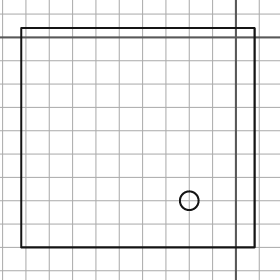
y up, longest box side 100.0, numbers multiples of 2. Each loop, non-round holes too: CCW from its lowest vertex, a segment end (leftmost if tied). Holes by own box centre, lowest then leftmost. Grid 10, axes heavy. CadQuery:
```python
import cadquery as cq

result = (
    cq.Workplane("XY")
    .moveTo(-92.0, -90.0)
    .lineTo(8.0, -90.0)
    .lineTo(8.0, 4.0)
    .lineTo(-92.0, 4.0)
    .close()
    .moveTo(-20.0, -70.0)
    .circle(4.0)
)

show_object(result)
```